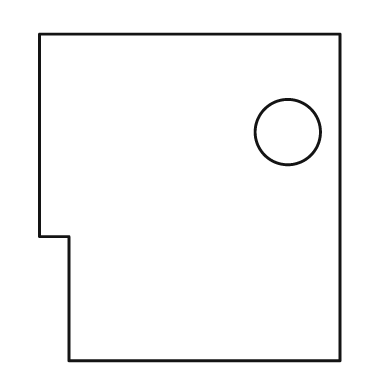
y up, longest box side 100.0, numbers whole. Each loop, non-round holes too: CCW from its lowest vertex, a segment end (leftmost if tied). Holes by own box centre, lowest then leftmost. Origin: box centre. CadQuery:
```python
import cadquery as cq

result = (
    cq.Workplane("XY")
    .moveTo(-37.0, -50.0)
    .lineTo(46.0, -50.0)
    .lineTo(46.0, 50.0)
    .lineTo(-46.0, 50.0)
    .lineTo(-46.0, -12.0)
    .lineTo(-37.0, -12.0)
    .close()
    .moveTo(30.0, 20.0)
    .circle(10.0)
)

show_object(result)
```